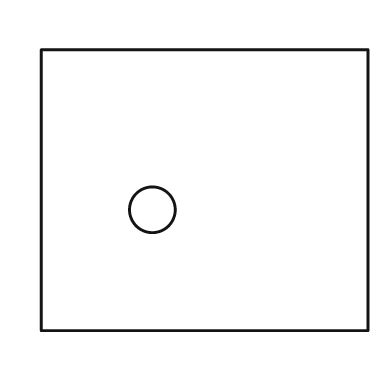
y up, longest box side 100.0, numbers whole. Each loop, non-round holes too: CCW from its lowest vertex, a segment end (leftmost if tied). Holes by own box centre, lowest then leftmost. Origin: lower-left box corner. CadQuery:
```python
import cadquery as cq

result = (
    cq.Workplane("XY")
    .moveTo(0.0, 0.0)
    .lineTo(100.0, 0.0)
    .lineTo(100.0, 86.0)
    .lineTo(0.0, 86.0)
    .close()
    .moveTo(34.0, 37.0)
    .circle(7.0)
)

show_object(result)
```